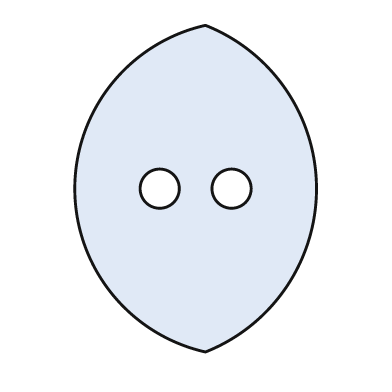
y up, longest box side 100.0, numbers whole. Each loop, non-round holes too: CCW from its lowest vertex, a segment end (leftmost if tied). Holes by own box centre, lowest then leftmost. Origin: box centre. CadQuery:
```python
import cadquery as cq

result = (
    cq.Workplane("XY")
    .moveTo(3.0, -50.0)
    .threePointArc((37.0, 0.0), (3.0, 50.0))
    .threePointArc((-37.0, 0.0), (3.0, -50.0))
    .close()
    .moveTo(-11.0, 0.0)
    .circle(6.0)
    .moveTo(11.0, 0.0)
    .circle(6.0)
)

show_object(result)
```